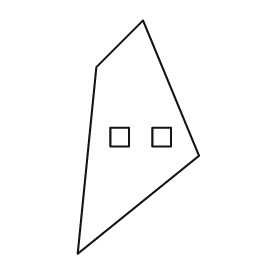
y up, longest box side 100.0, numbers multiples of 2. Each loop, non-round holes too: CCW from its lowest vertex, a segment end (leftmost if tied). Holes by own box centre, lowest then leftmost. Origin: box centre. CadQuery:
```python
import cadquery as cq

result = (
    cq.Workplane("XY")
    .moveTo(-26.0, -50.0)
    .lineTo(26.0, -8.0)
    .lineTo(2.0, 50.0)
    .lineTo(-18.0, 30.0)
    .close()
    .moveTo(-12.0, -4.0)
    .lineTo(-4.0, -4.0)
    .lineTo(-4.0, 4.0)
    .lineTo(-12.0, 4.0)
    .close()
    .moveTo(6.0, -4.0)
    .lineTo(14.0, -4.0)
    .lineTo(14.0, 4.0)
    .lineTo(6.0, 4.0)
    .close()
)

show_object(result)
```